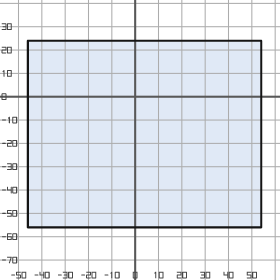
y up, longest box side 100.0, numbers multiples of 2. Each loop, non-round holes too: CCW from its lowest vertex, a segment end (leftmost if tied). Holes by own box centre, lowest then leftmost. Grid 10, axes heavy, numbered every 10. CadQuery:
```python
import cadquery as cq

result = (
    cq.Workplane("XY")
    .moveTo(-46.0, -56.0)
    .lineTo(54.0, -56.0)
    .lineTo(54.0, 24.0)
    .lineTo(-46.0, 24.0)
    .close()
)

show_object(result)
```